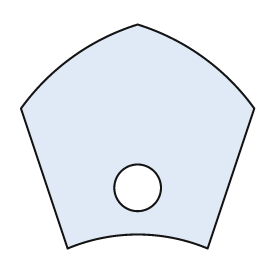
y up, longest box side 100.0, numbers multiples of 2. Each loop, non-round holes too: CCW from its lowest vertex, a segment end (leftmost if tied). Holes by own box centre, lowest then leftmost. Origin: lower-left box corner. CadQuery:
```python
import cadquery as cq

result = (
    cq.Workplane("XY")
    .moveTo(20.0, 0.0)
    .threePointArc((50.0, 6.0), (80.0, 0.0))
    .lineTo(100.0, 60.0)
    .threePointArc((78.0, 82.0), (50.0, 96.0))
    .threePointArc((22.0, 82.0), (0.0, 60.0))
    .close()
    .moveTo(50.0, 26.0)
    .circle(10.0)
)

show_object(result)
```